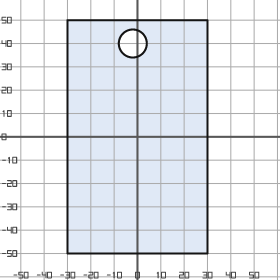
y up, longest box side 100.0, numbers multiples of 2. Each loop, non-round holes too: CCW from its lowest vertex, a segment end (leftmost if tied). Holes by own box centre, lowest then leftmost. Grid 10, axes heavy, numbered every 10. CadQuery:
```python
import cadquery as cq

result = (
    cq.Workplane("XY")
    .moveTo(-30.0, -50.0)
    .lineTo(30.0, -50.0)
    .lineTo(30.0, 50.0)
    .lineTo(-30.0, 50.0)
    .close()
    .moveTo(-2.0, 40.0)
    .circle(6.0)
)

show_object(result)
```